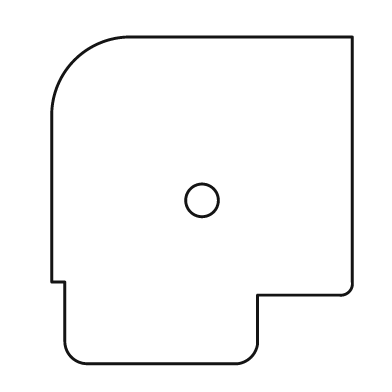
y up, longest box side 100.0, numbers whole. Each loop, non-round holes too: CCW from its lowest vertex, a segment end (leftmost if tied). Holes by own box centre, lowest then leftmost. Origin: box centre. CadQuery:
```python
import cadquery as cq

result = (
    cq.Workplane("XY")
    .moveTo(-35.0, -50.0)
    .lineTo(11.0, -50.0)
    .threePointArc((15.0, -48.0), (17.0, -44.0))
    .lineTo(17.0, -29.0)
    .lineTo(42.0, -29.0)
    .threePointArc((45.0, -28.0), (46.0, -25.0))
    .lineTo(46.0, 50.0)
    .lineTo(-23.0, 50.0)
    .threePointArc((-39.0, 43.0), (-46.0, 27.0))
    .lineTo(-46.0, -25.0)
    .lineTo(-42.0, -25.0)
    .lineTo(-42.0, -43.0)
    .threePointArc((-40.0, -48.0), (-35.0, -50.0))
    .close()
    .moveTo(0.0, 0.0)
    .circle(5.0)
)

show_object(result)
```